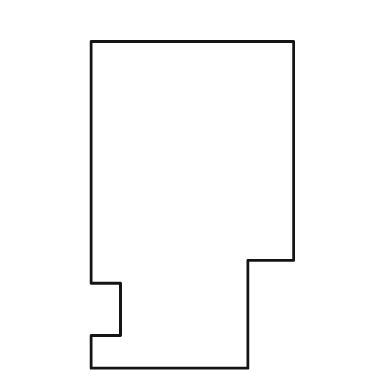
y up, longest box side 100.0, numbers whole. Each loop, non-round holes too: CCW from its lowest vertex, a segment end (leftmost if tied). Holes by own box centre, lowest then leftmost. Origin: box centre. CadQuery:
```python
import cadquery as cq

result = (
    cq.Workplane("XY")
    .moveTo(-31.0, -50.0)
    .lineTo(17.0, -50.0)
    .lineTo(17.0, -17.0)
    .lineTo(31.0, -17.0)
    .lineTo(31.0, 50.0)
    .lineTo(-31.0, 50.0)
    .lineTo(-31.0, -24.0)
    .lineTo(-22.0, -24.0)
    .lineTo(-22.0, -40.0)
    .lineTo(-31.0, -40.0)
    .close()
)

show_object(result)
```